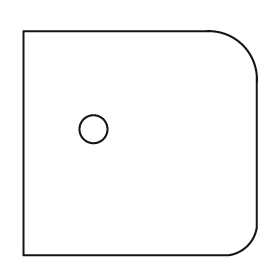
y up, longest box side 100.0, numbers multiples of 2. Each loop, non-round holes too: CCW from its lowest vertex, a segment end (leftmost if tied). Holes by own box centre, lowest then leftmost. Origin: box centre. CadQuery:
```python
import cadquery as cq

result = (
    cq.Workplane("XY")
    .moveTo(-50.0, -48.0)
    .lineTo(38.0, -48.0)
    .threePointArc((46.0, -44.0), (50.0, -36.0))
    .lineTo(50.0, 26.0)
    .threePointArc((44.0, 42.0), (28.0, 48.0))
    .lineTo(-50.0, 48.0)
    .close()
    .moveTo(-20.0, 6.0)
    .circle(6.0)
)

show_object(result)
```